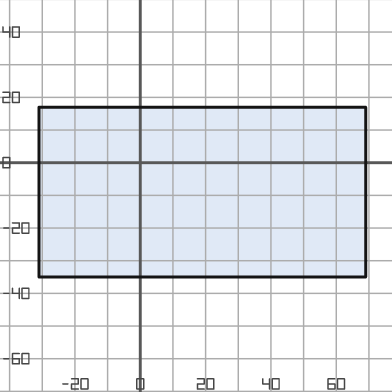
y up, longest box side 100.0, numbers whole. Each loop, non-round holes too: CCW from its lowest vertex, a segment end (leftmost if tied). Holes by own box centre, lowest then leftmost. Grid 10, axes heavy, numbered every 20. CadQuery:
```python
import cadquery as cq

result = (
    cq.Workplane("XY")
    .moveTo(-31.0, -35.0)
    .lineTo(69.0, -35.0)
    .lineTo(69.0, 17.0)
    .lineTo(-31.0, 17.0)
    .close()
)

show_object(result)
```